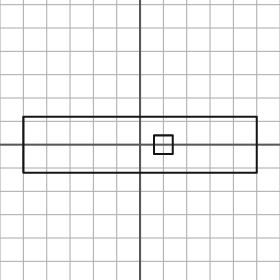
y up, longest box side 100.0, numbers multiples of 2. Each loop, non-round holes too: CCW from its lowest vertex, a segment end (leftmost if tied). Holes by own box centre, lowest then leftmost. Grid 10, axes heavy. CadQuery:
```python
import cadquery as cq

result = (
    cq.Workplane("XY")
    .moveTo(-50.0, -12.0)
    .lineTo(50.0, -12.0)
    .lineTo(50.0, 12.0)
    .lineTo(-50.0, 12.0)
    .close()
    .moveTo(6.0, -4.0)
    .lineTo(14.0, -4.0)
    .lineTo(14.0, 4.0)
    .lineTo(6.0, 4.0)
    .close()
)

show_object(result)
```